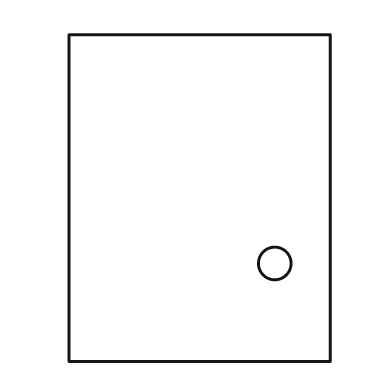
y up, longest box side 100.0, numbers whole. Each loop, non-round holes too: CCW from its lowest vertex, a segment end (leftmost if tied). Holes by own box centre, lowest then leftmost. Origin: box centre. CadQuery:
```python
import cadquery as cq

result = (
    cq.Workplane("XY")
    .moveTo(-40.0, -50.0)
    .lineTo(40.0, -50.0)
    .lineTo(40.0, 50.0)
    .lineTo(-40.0, 50.0)
    .close()
    .moveTo(23.0, -20.0)
    .circle(5.0)
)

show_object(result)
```